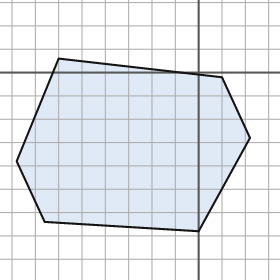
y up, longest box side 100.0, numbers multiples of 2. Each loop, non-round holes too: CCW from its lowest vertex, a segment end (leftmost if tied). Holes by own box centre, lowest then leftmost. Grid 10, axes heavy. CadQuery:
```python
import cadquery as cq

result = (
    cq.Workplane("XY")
    .moveTo(0.0, -68.0)
    .lineTo(22.0, -28.0)
    .lineTo(10.0, -2.0)
    .lineTo(-60.0, 6.0)
    .lineTo(-78.0, -38.0)
    .lineTo(-66.0, -64.0)
    .close()
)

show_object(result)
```